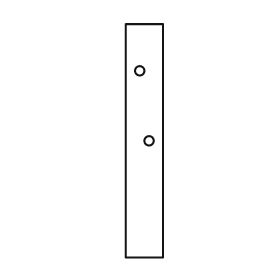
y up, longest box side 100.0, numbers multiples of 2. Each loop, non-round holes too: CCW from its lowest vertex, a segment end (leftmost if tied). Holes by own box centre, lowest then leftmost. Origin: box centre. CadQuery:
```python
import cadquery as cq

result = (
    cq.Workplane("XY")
    .moveTo(-8.0, -50.0)
    .lineTo(8.0, -50.0)
    .lineTo(8.0, 50.0)
    .lineTo(-8.0, 50.0)
    .close()
    .moveTo(2.0, 0.0)
    .circle(2.0)
    .moveTo(-2.0, 30.0)
    .circle(2.0)
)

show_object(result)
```